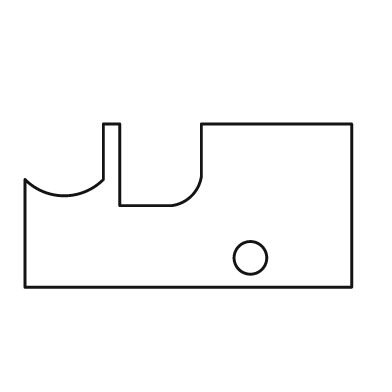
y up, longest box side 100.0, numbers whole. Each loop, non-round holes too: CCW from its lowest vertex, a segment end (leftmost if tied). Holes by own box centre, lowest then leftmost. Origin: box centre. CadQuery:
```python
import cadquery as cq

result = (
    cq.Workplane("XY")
    .moveTo(-50.0, -25.0)
    .lineTo(50.0, -25.0)
    .lineTo(50.0, 25.0)
    .lineTo(4.0, 25.0)
    .lineTo(4.0, 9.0)
    .threePointArc((1.0, 3.0), (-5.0, 0.0))
    .lineTo(-21.0, 0.0)
    .lineTo(-21.0, 25.0)
    .lineTo(-26.0, 25.0)
    .lineTo(-26.0, 8.0)
    .threePointArc((-38.0, 3.0), (-50.0, 8.0))
    .close()
    .moveTo(19.0, -16.0)
    .circle(5.0)
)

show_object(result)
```